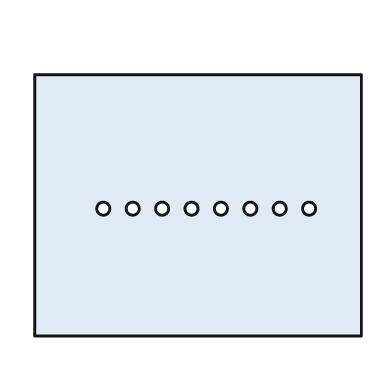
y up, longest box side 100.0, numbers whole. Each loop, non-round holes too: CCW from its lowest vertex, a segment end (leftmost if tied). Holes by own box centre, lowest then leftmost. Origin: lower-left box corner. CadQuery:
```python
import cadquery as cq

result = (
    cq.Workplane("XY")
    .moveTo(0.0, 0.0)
    .lineTo(100.0, 0.0)
    .lineTo(100.0, 80.0)
    .lineTo(0.0, 80.0)
    .close()
    .moveTo(21.0, 39.0)
    .circle(2.0)
    .moveTo(30.0, 39.0)
    .circle(2.0)
    .moveTo(39.0, 39.0)
    .circle(2.0)
    .moveTo(48.0, 39.0)
    .circle(2.0)
    .moveTo(57.0, 39.0)
    .circle(2.0)
    .moveTo(66.0, 39.0)
    .circle(2.0)
    .moveTo(75.0, 39.0)
    .circle(2.0)
    .moveTo(84.0, 39.0)
    .circle(2.0)
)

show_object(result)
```